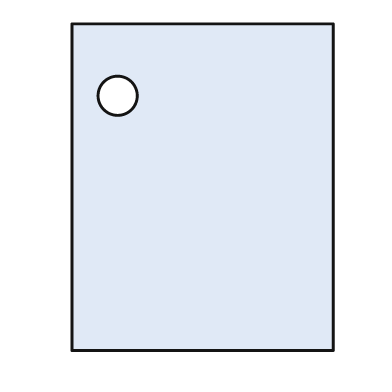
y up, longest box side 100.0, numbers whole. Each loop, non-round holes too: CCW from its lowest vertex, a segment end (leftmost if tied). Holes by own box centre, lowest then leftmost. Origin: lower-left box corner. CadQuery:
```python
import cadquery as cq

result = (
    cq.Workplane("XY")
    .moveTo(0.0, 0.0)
    .lineTo(80.0, 0.0)
    .lineTo(80.0, 100.0)
    .lineTo(0.0, 100.0)
    .close()
    .moveTo(14.0, 78.0)
    .circle(6.0)
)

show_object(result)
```